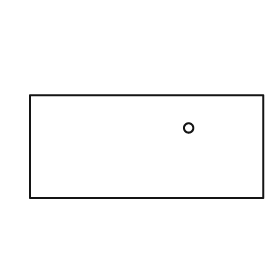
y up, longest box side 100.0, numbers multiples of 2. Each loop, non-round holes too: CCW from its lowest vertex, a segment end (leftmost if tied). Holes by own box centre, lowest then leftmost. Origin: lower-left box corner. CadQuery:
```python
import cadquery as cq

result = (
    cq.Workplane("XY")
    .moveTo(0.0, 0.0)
    .lineTo(100.0, 0.0)
    .lineTo(100.0, 44.0)
    .lineTo(0.0, 44.0)
    .close()
    .moveTo(68.0, 30.0)
    .circle(2.0)
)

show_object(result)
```